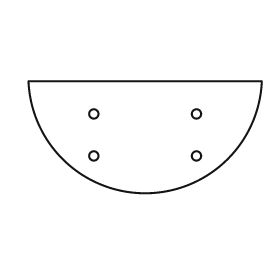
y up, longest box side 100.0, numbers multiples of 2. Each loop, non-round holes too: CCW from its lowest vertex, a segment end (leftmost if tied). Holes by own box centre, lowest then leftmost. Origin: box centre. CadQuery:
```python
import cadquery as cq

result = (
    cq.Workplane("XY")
    .moveTo(-50.0, 24.0)
    .threePointArc((0.0, -24.0), (50.0, 24.0))
    .close()
    .moveTo(-22.0, -8.0)
    .circle(2.0)
    .moveTo(22.0, -8.0)
    .circle(2.0)
    .moveTo(-22.0, 10.0)
    .circle(2.0)
    .moveTo(22.0, 10.0)
    .circle(2.0)
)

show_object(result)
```